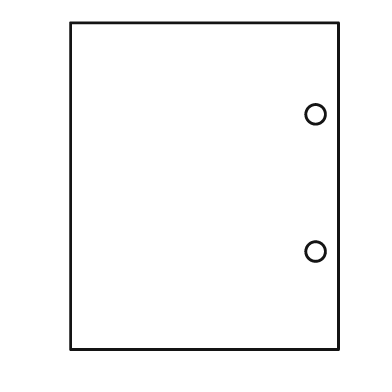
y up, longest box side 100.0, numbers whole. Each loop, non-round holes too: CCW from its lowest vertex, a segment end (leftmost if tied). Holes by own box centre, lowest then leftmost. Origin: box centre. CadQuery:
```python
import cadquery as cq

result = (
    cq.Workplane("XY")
    .moveTo(-41.0, -50.0)
    .lineTo(41.0, -50.0)
    .lineTo(41.0, 50.0)
    .lineTo(-41.0, 50.0)
    .close()
    .moveTo(34.0, -20.0)
    .circle(3.0)
    .moveTo(34.0, 22.0)
    .circle(3.0)
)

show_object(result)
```